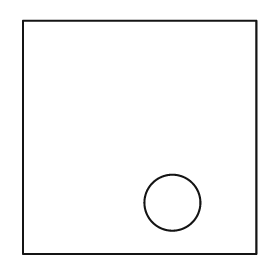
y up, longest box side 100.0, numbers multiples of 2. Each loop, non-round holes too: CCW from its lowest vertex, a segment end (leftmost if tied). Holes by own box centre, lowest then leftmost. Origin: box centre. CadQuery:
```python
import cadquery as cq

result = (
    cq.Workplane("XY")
    .moveTo(-50.0, -50.0)
    .lineTo(50.0, -50.0)
    .lineTo(50.0, 50.0)
    .lineTo(-50.0, 50.0)
    .close()
    .moveTo(14.0, -28.0)
    .circle(12.0)
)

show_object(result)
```